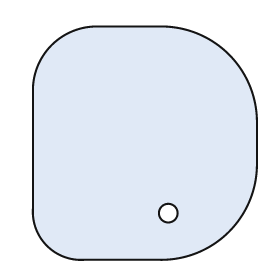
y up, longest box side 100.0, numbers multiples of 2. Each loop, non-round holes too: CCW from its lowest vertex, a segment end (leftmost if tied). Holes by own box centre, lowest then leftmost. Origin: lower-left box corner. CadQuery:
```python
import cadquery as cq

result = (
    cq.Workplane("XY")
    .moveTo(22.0, 0.0)
    .lineTo(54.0, 0.0)
    .threePointArc((84.0, 12.0), (96.0, 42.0))
    .lineTo(96.0, 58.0)
    .threePointArc((84.0, 88.0), (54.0, 100.0))
    .lineTo(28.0, 100.0)
    .threePointArc((8.0, 92.0), (0.0, 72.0))
    .lineTo(0.0, 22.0)
    .threePointArc((6.0, 6.0), (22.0, 0.0))
    .close()
    .moveTo(58.0, 20.0)
    .circle(4.0)
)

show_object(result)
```